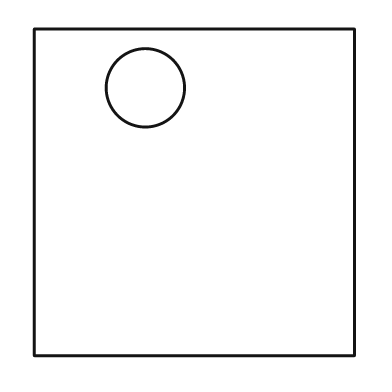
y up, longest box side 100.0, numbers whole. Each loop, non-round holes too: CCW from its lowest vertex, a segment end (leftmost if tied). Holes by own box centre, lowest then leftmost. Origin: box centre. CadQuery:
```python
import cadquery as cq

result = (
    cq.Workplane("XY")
    .moveTo(-49.0, -50.0)
    .lineTo(49.0, -50.0)
    .lineTo(49.0, 50.0)
    .lineTo(-49.0, 50.0)
    .close()
    .moveTo(-15.0, 32.0)
    .circle(12.0)
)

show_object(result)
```